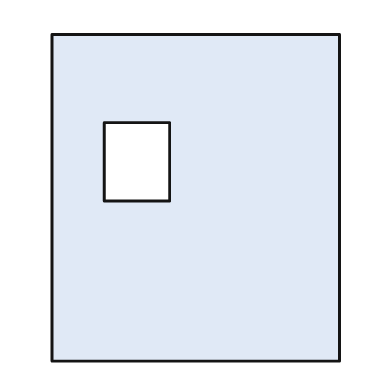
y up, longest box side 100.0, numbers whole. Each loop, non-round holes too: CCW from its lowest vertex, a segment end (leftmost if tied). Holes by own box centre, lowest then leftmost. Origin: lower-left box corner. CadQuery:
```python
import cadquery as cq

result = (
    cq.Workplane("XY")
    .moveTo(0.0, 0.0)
    .lineTo(88.0, 0.0)
    .lineTo(88.0, 100.0)
    .lineTo(0.0, 100.0)
    .close()
    .moveTo(16.0, 49.0)
    .lineTo(36.0, 49.0)
    .lineTo(36.0, 73.0)
    .lineTo(16.0, 73.0)
    .close()
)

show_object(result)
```